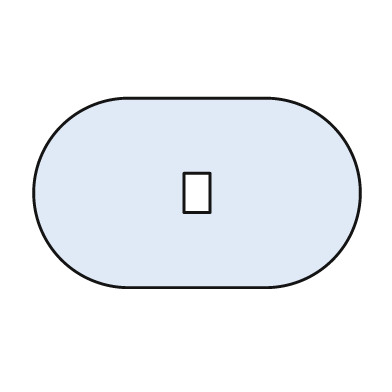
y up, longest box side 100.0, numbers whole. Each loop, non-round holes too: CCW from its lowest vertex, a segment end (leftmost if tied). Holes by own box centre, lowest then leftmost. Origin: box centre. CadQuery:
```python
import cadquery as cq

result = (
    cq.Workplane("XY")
    .moveTo(-21.0, -29.0)
    .lineTo(21.0, -29.0)
    .threePointArc((50.0, 0.0), (21.0, 29.0))
    .lineTo(-21.0, 29.0)
    .threePointArc((-50.0, 0.0), (-21.0, -29.0))
    .close()
    .moveTo(-4.0, -6.0)
    .lineTo(4.0, -6.0)
    .lineTo(4.0, 6.0)
    .lineTo(-4.0, 6.0)
    .close()
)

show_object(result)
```